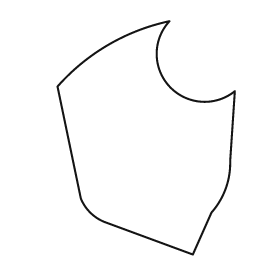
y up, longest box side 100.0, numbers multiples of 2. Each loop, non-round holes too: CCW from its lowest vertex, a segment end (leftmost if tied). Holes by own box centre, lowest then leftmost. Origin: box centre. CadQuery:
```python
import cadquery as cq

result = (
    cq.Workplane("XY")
    .moveTo(20.0, -50.0)
    .lineTo(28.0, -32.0)
    .threePointArc((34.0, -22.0), (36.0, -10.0))
    .lineTo(38.0, 20.0)
    .threePointArc((10.0, 22.0), (10.0, 50.0))
    .threePointArc((-16.0, 40.0), (-38.0, 22.0))
    .lineTo(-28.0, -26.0)
    .threePointArc((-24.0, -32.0), (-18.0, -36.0))
    .close()
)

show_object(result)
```